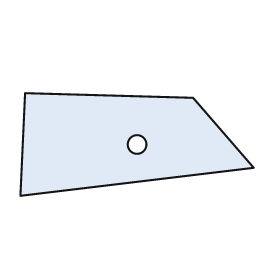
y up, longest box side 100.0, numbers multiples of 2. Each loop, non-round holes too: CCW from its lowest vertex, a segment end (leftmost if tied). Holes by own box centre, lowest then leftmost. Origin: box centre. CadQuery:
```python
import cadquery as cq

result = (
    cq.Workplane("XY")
    .moveTo(-50.0, -22.0)
    .lineTo(50.0, -10.0)
    .lineTo(24.0, 20.0)
    .lineTo(-48.0, 22.0)
    .close()
    .moveTo(0.0, 0.0)
    .circle(4.0)
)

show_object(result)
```